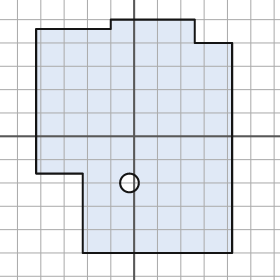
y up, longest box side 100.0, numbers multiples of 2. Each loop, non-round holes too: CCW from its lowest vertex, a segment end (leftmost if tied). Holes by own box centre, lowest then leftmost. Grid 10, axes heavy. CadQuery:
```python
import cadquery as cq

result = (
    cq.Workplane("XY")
    .moveTo(-22.0, -50.0)
    .lineTo(42.0, -50.0)
    .lineTo(42.0, 40.0)
    .lineTo(26.0, 40.0)
    .lineTo(26.0, 50.0)
    .lineTo(-10.0, 50.0)
    .lineTo(-10.0, 46.0)
    .lineTo(-42.0, 46.0)
    .lineTo(-42.0, -16.0)
    .lineTo(-22.0, -16.0)
    .close()
    .moveTo(-2.0, -20.0)
    .circle(4.0)
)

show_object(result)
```